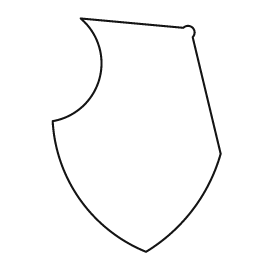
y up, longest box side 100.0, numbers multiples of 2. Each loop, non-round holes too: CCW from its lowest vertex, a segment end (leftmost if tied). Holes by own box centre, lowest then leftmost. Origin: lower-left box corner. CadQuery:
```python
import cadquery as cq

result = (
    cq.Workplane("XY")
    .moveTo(40.0, 0.0)
    .threePointArc((60.0, 18.0), (72.0, 42.0))
    .lineTo(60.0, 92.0)
    .threePointArc((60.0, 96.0), (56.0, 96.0))
    .lineTo(12.0, 100.0)
    .threePointArc((20.0, 74.0), (0.0, 56.0))
    .threePointArc((12.0, 22.0), (40.0, 0.0))
    .close()
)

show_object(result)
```